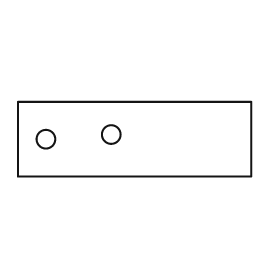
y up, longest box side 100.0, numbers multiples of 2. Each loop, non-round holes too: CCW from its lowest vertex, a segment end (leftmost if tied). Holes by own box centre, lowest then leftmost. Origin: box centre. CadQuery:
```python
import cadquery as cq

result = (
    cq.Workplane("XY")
    .moveTo(-50.0, -16.0)
    .lineTo(50.0, -16.0)
    .lineTo(50.0, 16.0)
    .lineTo(-50.0, 16.0)
    .close()
    .moveTo(-38.0, 0.0)
    .circle(4.0)
    .moveTo(-10.0, 2.0)
    .circle(4.0)
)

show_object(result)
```